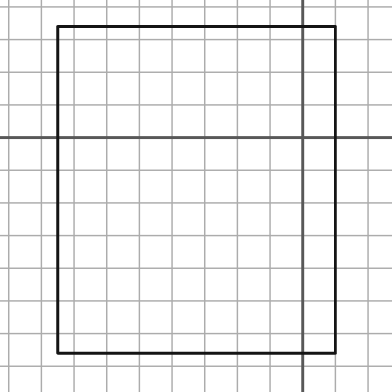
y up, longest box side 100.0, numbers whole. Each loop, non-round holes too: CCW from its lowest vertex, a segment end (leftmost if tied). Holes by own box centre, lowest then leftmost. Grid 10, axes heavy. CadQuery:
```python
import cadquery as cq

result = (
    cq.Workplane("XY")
    .moveTo(-75.0, -66.0)
    .lineTo(10.0, -66.0)
    .lineTo(10.0, 34.0)
    .lineTo(-75.0, 34.0)
    .close()
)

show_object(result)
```